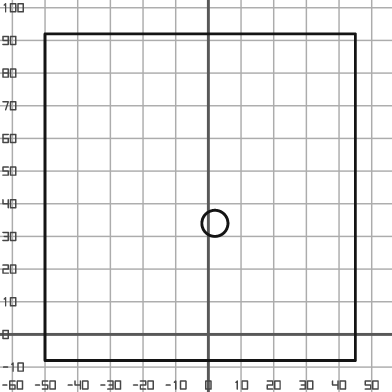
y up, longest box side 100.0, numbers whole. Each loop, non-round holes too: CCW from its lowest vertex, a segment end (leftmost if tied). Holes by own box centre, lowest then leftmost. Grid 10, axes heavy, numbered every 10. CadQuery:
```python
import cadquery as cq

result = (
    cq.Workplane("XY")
    .moveTo(-50.0, -8.0)
    .lineTo(45.0, -8.0)
    .lineTo(45.0, 92.0)
    .lineTo(-50.0, 92.0)
    .close()
    .moveTo(2.0, 34.0)
    .circle(4.0)
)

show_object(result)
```